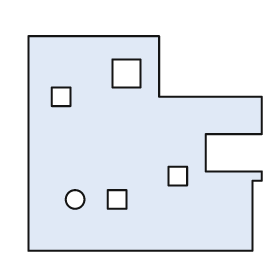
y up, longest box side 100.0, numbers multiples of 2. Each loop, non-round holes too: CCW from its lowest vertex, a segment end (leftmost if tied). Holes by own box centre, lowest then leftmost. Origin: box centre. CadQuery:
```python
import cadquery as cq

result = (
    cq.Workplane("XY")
    .moveTo(-50.0, -46.0)
    .lineTo(46.0, -46.0)
    .lineTo(46.0, -16.0)
    .lineTo(50.0, -16.0)
    .lineTo(50.0, -12.0)
    .lineTo(26.0, -12.0)
    .lineTo(26.0, 4.0)
    .lineTo(50.0, 4.0)
    .lineTo(50.0, 20.0)
    .lineTo(6.0, 20.0)
    .lineTo(6.0, 46.0)
    .lineTo(-50.0, 46.0)
    .close()
    .moveTo(-30.0, -24.0)
    .circle(4.0)
    .moveTo(-16.0, -28.0)
    .lineTo(-8.0, -28.0)
    .lineTo(-8.0, -20.0)
    .lineTo(-16.0, -20.0)
    .close()
    .moveTo(10.0, -18.0)
    .lineTo(18.0, -18.0)
    .lineTo(18.0, -10.0)
    .lineTo(10.0, -10.0)
    .close()
    .moveTo(-40.0, 16.0)
    .lineTo(-32.0, 16.0)
    .lineTo(-32.0, 24.0)
    .lineTo(-40.0, 24.0)
    .close()
    .moveTo(-14.0, 24.0)
    .lineTo(-2.0, 24.0)
    .lineTo(-2.0, 36.0)
    .lineTo(-14.0, 36.0)
    .close()
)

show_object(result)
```